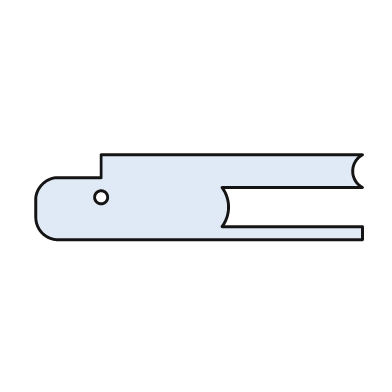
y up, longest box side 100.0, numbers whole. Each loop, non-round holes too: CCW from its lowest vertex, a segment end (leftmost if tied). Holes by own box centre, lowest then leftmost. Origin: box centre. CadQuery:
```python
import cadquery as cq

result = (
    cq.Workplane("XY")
    .moveTo(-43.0, -13.0)
    .lineTo(50.0, -13.0)
    .lineTo(50.0, -9.0)
    .lineTo(7.0, -9.0)
    .threePointArc((9.0, -3.0), (7.0, 3.0))
    .lineTo(50.0, 3.0)
    .threePointArc((47.0, 8.0), (50.0, 13.0))
    .lineTo(-30.0, 13.0)
    .lineTo(-30.0, 6.0)
    .lineTo(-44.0, 6.0)
    .threePointArc((-48.0, 4.0), (-50.0, 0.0))
    .lineTo(-50.0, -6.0)
    .threePointArc((-48.0, -11.0), (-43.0, -13.0))
    .close()
    .moveTo(-30.0, 0.0)
    .circle(2.0)
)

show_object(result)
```